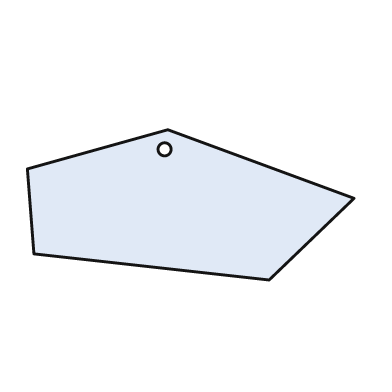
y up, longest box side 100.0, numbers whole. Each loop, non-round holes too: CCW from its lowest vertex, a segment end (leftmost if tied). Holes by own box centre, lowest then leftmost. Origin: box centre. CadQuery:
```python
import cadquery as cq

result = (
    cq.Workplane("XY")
    .moveTo(24.0, -23.0)
    .lineTo(50.0, 2.0)
    .lineTo(-7.0, 23.0)
    .lineTo(-50.0, 11.0)
    .lineTo(-48.0, -15.0)
    .close()
    .moveTo(-8.0, 17.0)
    .circle(2.0)
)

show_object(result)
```